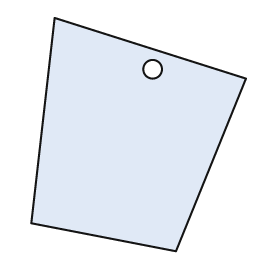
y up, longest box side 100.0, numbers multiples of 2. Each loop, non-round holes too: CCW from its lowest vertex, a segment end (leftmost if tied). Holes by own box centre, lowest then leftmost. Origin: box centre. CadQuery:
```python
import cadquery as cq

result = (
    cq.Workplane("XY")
    .moveTo(16.0, -50.0)
    .lineTo(46.0, 24.0)
    .lineTo(-36.0, 50.0)
    .lineTo(-46.0, -38.0)
    .close()
    .moveTo(6.0, 28.0)
    .circle(4.0)
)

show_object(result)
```